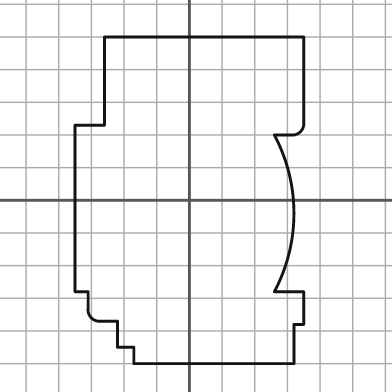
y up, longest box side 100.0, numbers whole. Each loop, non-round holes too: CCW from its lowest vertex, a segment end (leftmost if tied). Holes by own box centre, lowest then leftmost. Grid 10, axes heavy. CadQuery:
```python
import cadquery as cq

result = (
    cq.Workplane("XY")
    .moveTo(-17.0, -50.0)
    .lineTo(32.0, -50.0)
    .lineTo(32.0, -38.0)
    .lineTo(35.0, -38.0)
    .lineTo(35.0, -28.0)
    .lineTo(26.0, -28.0)
    .threePointArc((32.0, -4.0), (26.0, 20.0))
    .lineTo(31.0, 20.0)
    .threePointArc((34.0, 21.0), (35.0, 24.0))
    .lineTo(35.0, 50.0)
    .lineTo(-26.0, 50.0)
    .lineTo(-26.0, 23.0)
    .lineTo(-35.0, 23.0)
    .lineTo(-35.0, -28.0)
    .lineTo(-31.0, -28.0)
    .lineTo(-31.0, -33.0)
    .threePointArc((-30.0, -36.0), (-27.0, -37.0))
    .lineTo(-22.0, -37.0)
    .lineTo(-22.0, -45.0)
    .lineTo(-17.0, -45.0)
    .close()
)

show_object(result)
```